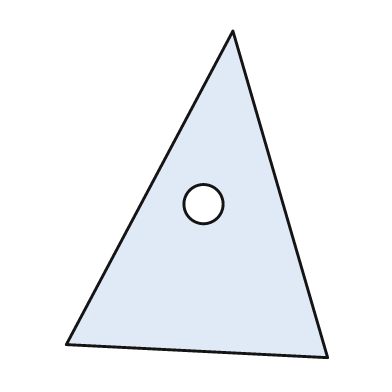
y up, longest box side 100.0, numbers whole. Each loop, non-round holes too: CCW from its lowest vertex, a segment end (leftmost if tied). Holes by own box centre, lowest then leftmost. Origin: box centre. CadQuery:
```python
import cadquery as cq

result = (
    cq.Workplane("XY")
    .moveTo(40.0, -50.0)
    .lineTo(11.0, 50.0)
    .lineTo(-40.0, -46.0)
    .close()
    .moveTo(2.0, -3.0)
    .circle(6.0)
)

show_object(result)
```